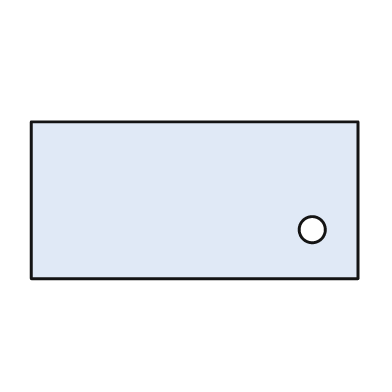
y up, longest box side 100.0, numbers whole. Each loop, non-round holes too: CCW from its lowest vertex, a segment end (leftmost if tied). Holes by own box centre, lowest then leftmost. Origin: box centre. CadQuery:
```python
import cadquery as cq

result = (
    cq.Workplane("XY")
    .moveTo(-50.0, -24.0)
    .lineTo(50.0, -24.0)
    .lineTo(50.0, 24.0)
    .lineTo(-50.0, 24.0)
    .close()
    .moveTo(36.0, -9.0)
    .circle(4.0)
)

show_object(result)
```